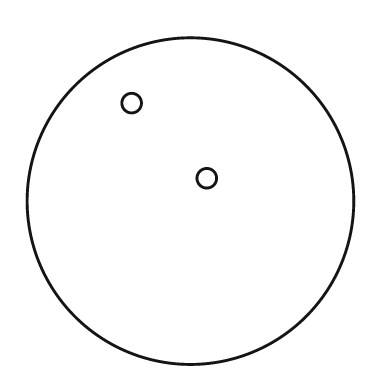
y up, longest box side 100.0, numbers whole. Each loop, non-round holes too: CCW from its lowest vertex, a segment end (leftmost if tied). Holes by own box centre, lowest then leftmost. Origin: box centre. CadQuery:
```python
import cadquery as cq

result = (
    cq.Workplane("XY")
    .moveTo(0.0, 0.0)
    .circle(50.0)
    .moveTo(5.0, 7.0)
    .circle(3.0)
    .moveTo(-18.0, 30.0)
    .circle(3.0)
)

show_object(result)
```